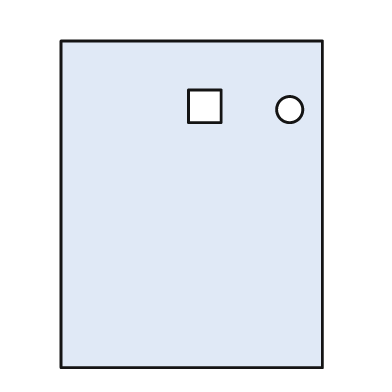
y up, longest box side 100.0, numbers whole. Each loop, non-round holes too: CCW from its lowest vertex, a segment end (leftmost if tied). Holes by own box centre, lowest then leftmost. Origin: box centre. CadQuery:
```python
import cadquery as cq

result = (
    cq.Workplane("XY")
    .moveTo(-40.0, -50.0)
    .lineTo(40.0, -50.0)
    .lineTo(40.0, 50.0)
    .lineTo(-40.0, 50.0)
    .close()
    .moveTo(30.0, 29.0)
    .circle(4.0)
    .moveTo(-1.0, 25.0)
    .lineTo(9.0, 25.0)
    .lineTo(9.0, 35.0)
    .lineTo(-1.0, 35.0)
    .close()
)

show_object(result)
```